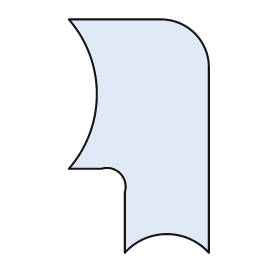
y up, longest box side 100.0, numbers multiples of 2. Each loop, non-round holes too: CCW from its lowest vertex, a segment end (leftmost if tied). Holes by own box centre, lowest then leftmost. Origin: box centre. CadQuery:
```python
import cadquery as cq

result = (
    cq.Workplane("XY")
    .moveTo(-6.0, -50.0)
    .threePointArc((12.0, -42.0), (30.0, -50.0))
    .lineTo(30.0, 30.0)
    .threePointArc((24.0, 44.0), (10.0, 50.0))
    .lineTo(-30.0, 50.0)
    .threePointArc((-18.0, 18.0), (-30.0, -14.0))
    .lineTo(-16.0, -14.0)
    .threePointArc((-8.0, -16.0), (-6.0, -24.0))
    .close()
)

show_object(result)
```